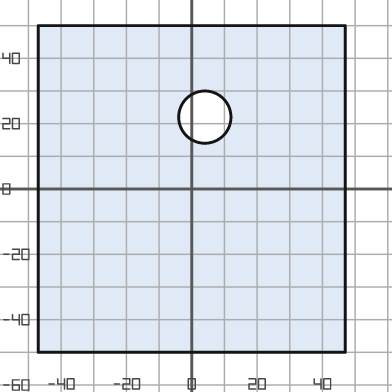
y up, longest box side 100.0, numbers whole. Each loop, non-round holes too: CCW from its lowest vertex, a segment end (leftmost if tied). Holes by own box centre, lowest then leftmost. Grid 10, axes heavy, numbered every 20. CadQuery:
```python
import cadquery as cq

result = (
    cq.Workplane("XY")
    .moveTo(-47.0, -50.0)
    .lineTo(47.0, -50.0)
    .lineTo(47.0, 50.0)
    .lineTo(-47.0, 50.0)
    .close()
    .moveTo(4.0, 22.0)
    .circle(8.0)
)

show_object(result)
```